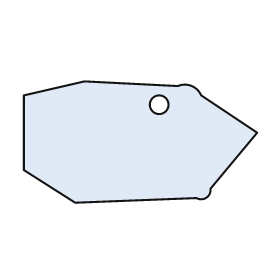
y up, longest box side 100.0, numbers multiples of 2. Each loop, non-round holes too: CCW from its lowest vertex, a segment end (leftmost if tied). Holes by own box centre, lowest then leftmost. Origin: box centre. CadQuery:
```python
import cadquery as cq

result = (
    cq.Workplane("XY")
    .moveTo(-28.0, -26.0)
    .lineTo(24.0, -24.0)
    .threePointArc((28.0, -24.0), (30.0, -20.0))
    .lineTo(50.0, 4.0)
    .lineTo(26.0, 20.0)
    .threePointArc((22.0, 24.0), (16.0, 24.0))
    .lineTo(-24.0, 26.0)
    .lineTo(-50.0, 20.0)
    .lineTo(-50.0, -12.0)
    .close()
    .moveTo(8.0, 16.0)
    .circle(4.0)
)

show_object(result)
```